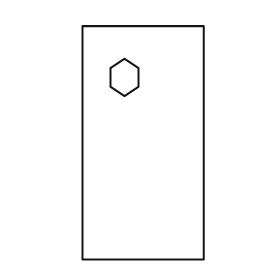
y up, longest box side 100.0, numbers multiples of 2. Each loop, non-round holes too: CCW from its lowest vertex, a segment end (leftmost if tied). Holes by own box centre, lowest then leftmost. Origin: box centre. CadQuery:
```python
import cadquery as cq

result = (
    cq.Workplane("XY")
    .moveTo(-26.0, -50.0)
    .lineTo(26.0, -50.0)
    .lineTo(26.0, 50.0)
    .lineTo(-26.0, 50.0)
    .close()
    .moveTo(-8.0, 20.0)
    .lineTo(-2.0, 24.0)
    .lineTo(-2.0, 32.0)
    .lineTo(-8.0, 36.0)
    .lineTo(-14.0, 32.0)
    .lineTo(-14.0, 24.0)
    .close()
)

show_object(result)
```